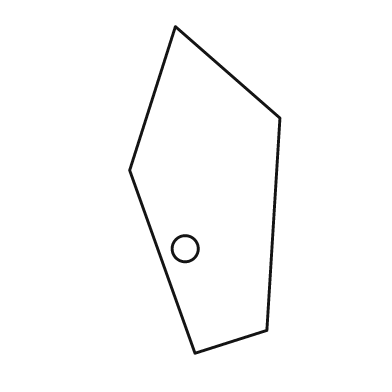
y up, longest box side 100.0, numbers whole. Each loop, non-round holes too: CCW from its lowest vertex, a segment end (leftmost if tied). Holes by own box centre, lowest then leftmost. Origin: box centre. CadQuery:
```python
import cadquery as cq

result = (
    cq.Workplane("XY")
    .moveTo(-3.0, -50.0)
    .lineTo(19.0, -43.0)
    .lineTo(23.0, 22.0)
    .lineTo(-9.0, 50.0)
    .lineTo(-23.0, 6.0)
    .close()
    .moveTo(-6.0, -18.0)
    .circle(4.0)
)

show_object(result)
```